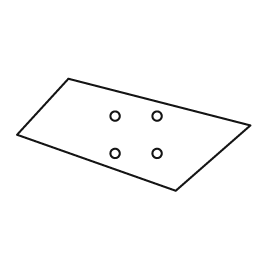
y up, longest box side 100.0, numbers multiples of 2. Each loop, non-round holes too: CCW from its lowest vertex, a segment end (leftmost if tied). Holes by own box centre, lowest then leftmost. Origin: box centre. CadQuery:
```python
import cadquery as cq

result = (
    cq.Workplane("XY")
    .moveTo(18.0, -24.0)
    .lineTo(50.0, 4.0)
    .lineTo(-28.0, 24.0)
    .lineTo(-50.0, 0.0)
    .close()
    .moveTo(-8.0, -8.0)
    .circle(2.0)
    .moveTo(10.0, -8.0)
    .circle(2.0)
    .moveTo(-8.0, 8.0)
    .circle(2.0)
    .moveTo(10.0, 8.0)
    .circle(2.0)
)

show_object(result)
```